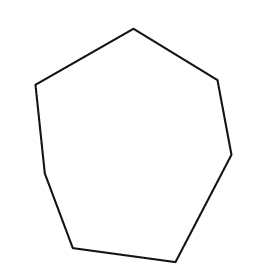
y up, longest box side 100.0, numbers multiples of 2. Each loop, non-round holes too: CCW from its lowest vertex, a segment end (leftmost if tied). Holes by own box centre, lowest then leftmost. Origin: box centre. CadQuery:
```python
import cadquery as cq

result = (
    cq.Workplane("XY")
    .moveTo(18.0, -50.0)
    .lineTo(42.0, -4.0)
    .lineTo(36.0, 28.0)
    .lineTo(0.0, 50.0)
    .lineTo(-42.0, 26.0)
    .lineTo(-38.0, -12.0)
    .lineTo(-26.0, -44.0)
    .close()
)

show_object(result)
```